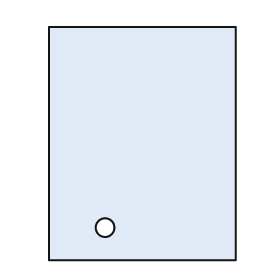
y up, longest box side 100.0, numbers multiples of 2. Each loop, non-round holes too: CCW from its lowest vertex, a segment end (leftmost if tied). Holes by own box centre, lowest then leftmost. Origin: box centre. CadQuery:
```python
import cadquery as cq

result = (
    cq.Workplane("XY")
    .moveTo(-40.0, -50.0)
    .lineTo(40.0, -50.0)
    .lineTo(40.0, 50.0)
    .lineTo(-40.0, 50.0)
    .close()
    .moveTo(-16.0, -36.0)
    .circle(4.0)
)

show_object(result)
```